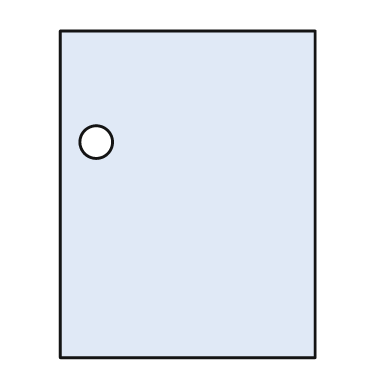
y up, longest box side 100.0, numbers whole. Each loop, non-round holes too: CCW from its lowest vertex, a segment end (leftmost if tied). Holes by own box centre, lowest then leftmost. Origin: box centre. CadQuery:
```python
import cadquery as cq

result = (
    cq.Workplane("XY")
    .moveTo(-39.0, -50.0)
    .lineTo(39.0, -50.0)
    .lineTo(39.0, 50.0)
    .lineTo(-39.0, 50.0)
    .close()
    .moveTo(-28.0, 16.0)
    .circle(5.0)
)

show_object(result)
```